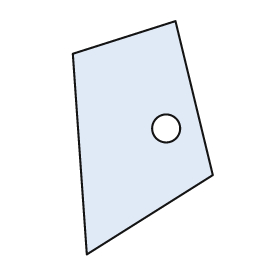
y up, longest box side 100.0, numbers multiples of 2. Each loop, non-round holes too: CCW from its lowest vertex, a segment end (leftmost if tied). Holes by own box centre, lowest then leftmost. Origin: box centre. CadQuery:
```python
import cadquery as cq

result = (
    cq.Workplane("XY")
    .moveTo(-24.0, -50.0)
    .lineTo(30.0, -16.0)
    .lineTo(14.0, 50.0)
    .lineTo(-30.0, 36.0)
    .close()
    .moveTo(10.0, 4.0)
    .circle(6.0)
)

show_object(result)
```